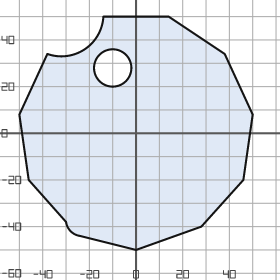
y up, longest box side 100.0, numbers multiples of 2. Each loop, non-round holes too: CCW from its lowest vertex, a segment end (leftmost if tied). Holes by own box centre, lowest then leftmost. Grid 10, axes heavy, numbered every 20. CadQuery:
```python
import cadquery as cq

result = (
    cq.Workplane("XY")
    .moveTo(0.0, -50.0)
    .lineTo(28.0, -40.0)
    .lineTo(46.0, -20.0)
    .lineTo(50.0, 8.0)
    .lineTo(38.0, 34.0)
    .lineTo(14.0, 50.0)
    .lineTo(-14.0, 50.0)
    .threePointArc((-22.0, 36.0), (-38.0, 34.0))
    .lineTo(-50.0, 8.0)
    .lineTo(-46.0, -20.0)
    .lineTo(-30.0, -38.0)
    .threePointArc((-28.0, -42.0), (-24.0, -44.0))
    .close()
    .moveTo(-10.0, 28.0)
    .circle(8.0)
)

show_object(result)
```